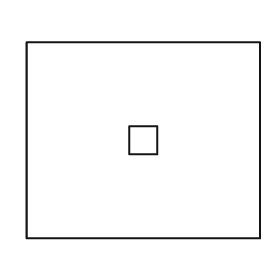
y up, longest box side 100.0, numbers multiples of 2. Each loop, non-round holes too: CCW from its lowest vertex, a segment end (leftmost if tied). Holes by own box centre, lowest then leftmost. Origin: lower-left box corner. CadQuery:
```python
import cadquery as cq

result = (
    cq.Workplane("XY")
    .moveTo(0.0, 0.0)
    .lineTo(100.0, 0.0)
    .lineTo(100.0, 84.0)
    .lineTo(0.0, 84.0)
    .close()
    .moveTo(44.0, 36.0)
    .lineTo(56.0, 36.0)
    .lineTo(56.0, 48.0)
    .lineTo(44.0, 48.0)
    .close()
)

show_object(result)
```